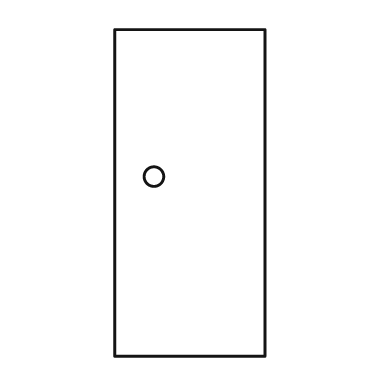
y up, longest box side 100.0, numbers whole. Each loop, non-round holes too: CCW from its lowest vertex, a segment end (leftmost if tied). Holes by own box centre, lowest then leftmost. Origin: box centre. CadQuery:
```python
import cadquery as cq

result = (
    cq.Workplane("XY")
    .moveTo(-23.0, -50.0)
    .lineTo(23.0, -50.0)
    .lineTo(23.0, 50.0)
    .lineTo(-23.0, 50.0)
    .close()
    .moveTo(-11.0, 5.0)
    .circle(3.0)
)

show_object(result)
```